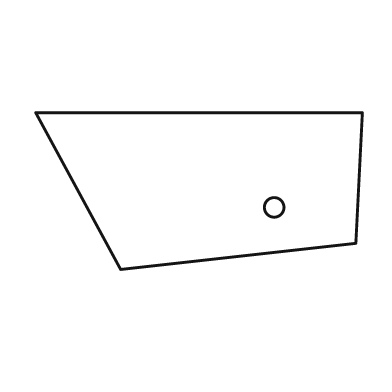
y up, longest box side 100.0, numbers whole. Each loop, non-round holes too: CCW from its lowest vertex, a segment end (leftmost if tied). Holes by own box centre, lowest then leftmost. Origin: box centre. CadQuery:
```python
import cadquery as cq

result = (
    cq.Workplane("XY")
    .moveTo(-24.0, -24.0)
    .lineTo(48.0, -16.0)
    .lineTo(50.0, 24.0)
    .lineTo(-50.0, 24.0)
    .close()
    .moveTo(23.0, -5.0)
    .circle(3.0)
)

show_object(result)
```